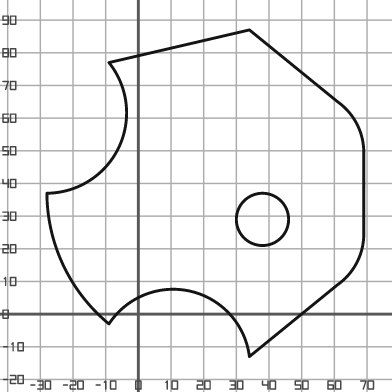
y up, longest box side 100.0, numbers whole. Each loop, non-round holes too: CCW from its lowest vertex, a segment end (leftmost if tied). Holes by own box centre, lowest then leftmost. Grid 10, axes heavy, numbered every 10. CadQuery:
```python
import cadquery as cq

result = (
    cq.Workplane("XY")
    .moveTo(34.0, -13.0)
    .lineTo(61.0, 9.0)
    .threePointArc((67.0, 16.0), (69.0, 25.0))
    .lineTo(69.0, 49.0)
    .threePointArc((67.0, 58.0), (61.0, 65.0))
    .lineTo(34.0, 87.0)
    .lineTo(-9.0, 77.0)
    .threePointArc((-6.0, 51.0), (-28.0, 37.0))
    .threePointArc((-23.0, 15.0), (-9.0, -3.0))
    .threePointArc((16.0, 7.0), (34.0, -13.0))
    .close()
    .moveTo(38.0, 29.0)
    .circle(8.0)
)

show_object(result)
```